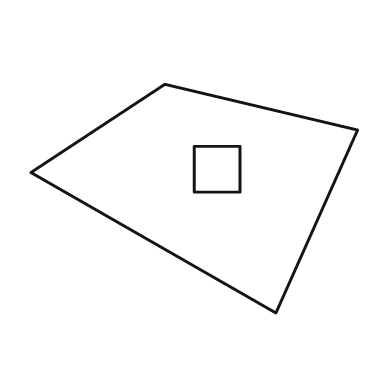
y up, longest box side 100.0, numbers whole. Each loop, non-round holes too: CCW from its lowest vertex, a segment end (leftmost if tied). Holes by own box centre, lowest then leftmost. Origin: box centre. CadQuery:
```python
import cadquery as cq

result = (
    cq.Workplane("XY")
    .moveTo(25.0, -35.0)
    .lineTo(50.0, 21.0)
    .lineTo(-9.0, 35.0)
    .lineTo(-50.0, 8.0)
    .close()
    .moveTo(0.0, 2.0)
    .lineTo(14.0, 2.0)
    .lineTo(14.0, 16.0)
    .lineTo(0.0, 16.0)
    .close()
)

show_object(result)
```